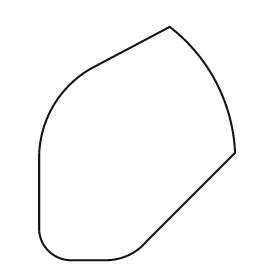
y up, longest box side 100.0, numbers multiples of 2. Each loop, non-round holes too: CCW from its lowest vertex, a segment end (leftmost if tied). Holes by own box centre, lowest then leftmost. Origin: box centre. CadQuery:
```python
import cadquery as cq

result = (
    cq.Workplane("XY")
    .moveTo(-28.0, -50.0)
    .lineTo(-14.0, -50.0)
    .threePointArc((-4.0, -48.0), (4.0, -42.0))
    .lineTo(42.0, -4.0)
    .threePointArc((34.0, 26.0), (14.0, 50.0))
    .lineTo(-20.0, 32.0)
    .threePointArc((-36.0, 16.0), (-42.0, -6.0))
    .lineTo(-42.0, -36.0)
    .threePointArc((-38.0, -46.0), (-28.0, -50.0))
    .close()
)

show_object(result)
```